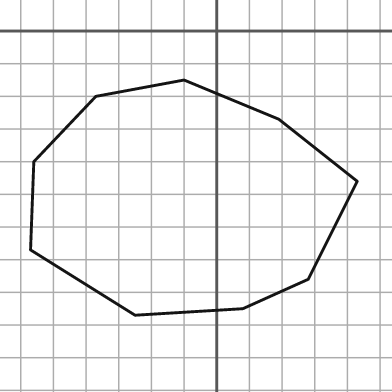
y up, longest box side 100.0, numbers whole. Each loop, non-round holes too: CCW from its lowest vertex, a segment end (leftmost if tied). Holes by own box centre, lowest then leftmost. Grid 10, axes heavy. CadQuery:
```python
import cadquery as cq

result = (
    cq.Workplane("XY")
    .moveTo(-25.0, -87.0)
    .lineTo(8.0, -85.0)
    .lineTo(28.0, -76.0)
    .lineTo(43.0, -46.0)
    .lineTo(19.0, -27.0)
    .lineTo(-10.0, -15.0)
    .lineTo(-37.0, -20.0)
    .lineTo(-56.0, -40.0)
    .lineTo(-57.0, -67.0)
    .close()
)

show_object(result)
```